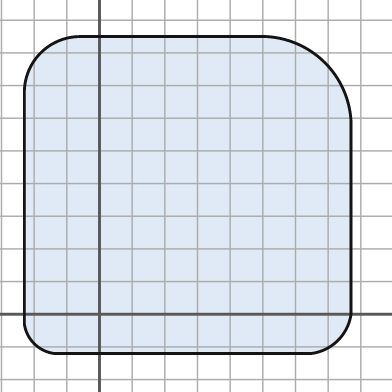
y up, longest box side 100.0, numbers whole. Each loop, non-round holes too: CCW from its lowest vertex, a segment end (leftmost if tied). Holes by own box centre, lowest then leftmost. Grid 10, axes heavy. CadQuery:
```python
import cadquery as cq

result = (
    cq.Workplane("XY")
    .moveTo(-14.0, -12.0)
    .lineTo(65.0, -12.0)
    .threePointArc((73.0, -8.0), (77.0, 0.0))
    .lineTo(77.0, 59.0)
    .threePointArc((69.0, 77.0), (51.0, 85.0))
    .lineTo(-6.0, 85.0)
    .threePointArc((-18.0, 80.0), (-23.0, 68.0))
    .lineTo(-23.0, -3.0)
    .threePointArc((-20.0, -9.0), (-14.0, -12.0))
    .close()
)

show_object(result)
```